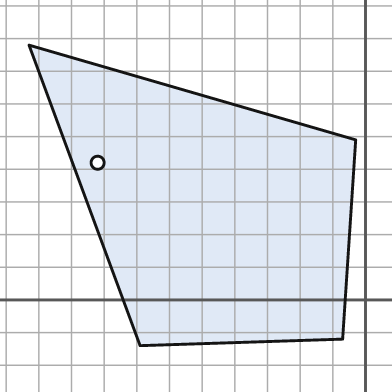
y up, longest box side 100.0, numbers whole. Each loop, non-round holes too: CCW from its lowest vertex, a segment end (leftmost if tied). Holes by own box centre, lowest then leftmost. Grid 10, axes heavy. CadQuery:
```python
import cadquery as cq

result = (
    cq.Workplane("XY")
    .moveTo(-69.0, -14.0)
    .lineTo(-7.0, -12.0)
    .lineTo(-3.0, 49.0)
    .lineTo(-103.0, 78.0)
    .close()
    .moveTo(-82.0, 42.0)
    .circle(2.0)
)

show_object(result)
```